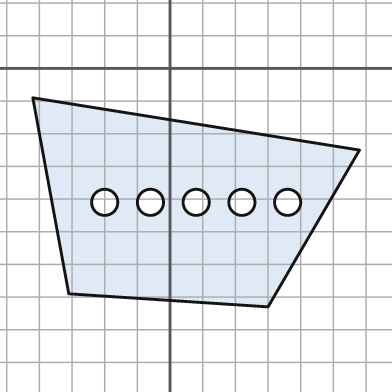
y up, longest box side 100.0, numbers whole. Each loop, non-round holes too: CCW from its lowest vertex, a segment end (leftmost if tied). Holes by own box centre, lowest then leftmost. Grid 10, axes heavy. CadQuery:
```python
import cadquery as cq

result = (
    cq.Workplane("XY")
    .moveTo(30.0, -73.0)
    .lineTo(58.0, -25.0)
    .lineTo(-42.0, -9.0)
    .lineTo(-31.0, -69.0)
    .close()
    .moveTo(-20.0, -41.0)
    .circle(4.0)
    .moveTo(-6.0, -41.0)
    .circle(4.0)
    .moveTo(8.0, -41.0)
    .circle(4.0)
    .moveTo(22.0, -41.0)
    .circle(4.0)
    .moveTo(36.0, -41.0)
    .circle(4.0)
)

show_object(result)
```